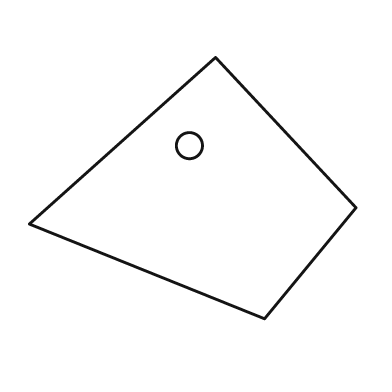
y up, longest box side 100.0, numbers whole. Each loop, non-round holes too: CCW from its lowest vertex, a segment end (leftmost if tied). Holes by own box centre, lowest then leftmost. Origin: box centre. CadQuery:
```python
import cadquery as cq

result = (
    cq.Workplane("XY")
    .moveTo(22.0, -40.0)
    .lineTo(50.0, -6.0)
    .lineTo(7.0, 40.0)
    .lineTo(-50.0, -11.0)
    .close()
    .moveTo(-1.0, 13.0)
    .circle(4.0)
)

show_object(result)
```